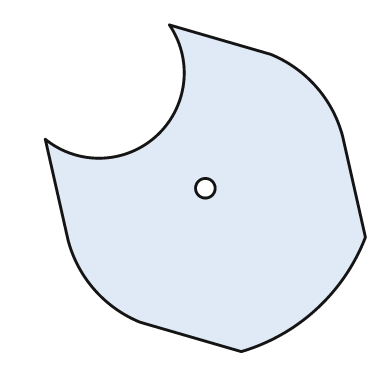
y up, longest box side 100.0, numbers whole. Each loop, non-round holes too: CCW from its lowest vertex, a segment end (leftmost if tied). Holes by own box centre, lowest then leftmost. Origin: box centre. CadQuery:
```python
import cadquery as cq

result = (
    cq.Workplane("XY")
    .moveTo(11.0, -50.0)
    .threePointArc((34.0, -37.0), (49.0, -15.0))
    .lineTo(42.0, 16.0)
    .threePointArc((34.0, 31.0), (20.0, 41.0))
    .lineTo(-11.0, 50.0)
    .threePointArc((-15.0, 16.0), (-49.0, 15.0))
    .lineTo(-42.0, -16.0)
    .threePointArc((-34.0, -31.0), (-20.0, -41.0))
    .close()
    .moveTo(0.0, 0.0)
    .circle(3.0)
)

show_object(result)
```